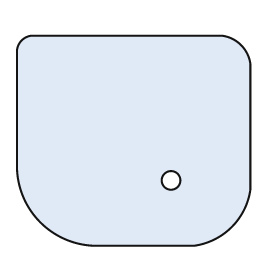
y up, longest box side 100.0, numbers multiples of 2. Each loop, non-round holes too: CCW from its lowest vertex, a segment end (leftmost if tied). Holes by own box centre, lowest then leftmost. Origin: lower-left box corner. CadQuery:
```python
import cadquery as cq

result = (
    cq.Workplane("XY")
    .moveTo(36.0, 0.0)
    .lineTo(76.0, 0.0)
    .threePointArc((92.0, 8.0), (100.0, 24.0))
    .lineTo(100.0, 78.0)
    .threePointArc((96.0, 86.0), (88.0, 90.0))
    .lineTo(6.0, 90.0)
    .threePointArc((2.0, 88.0), (0.0, 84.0))
    .lineTo(0.0, 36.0)
    .threePointArc((10.0, 10.0), (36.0, 0.0))
    .close()
    .moveTo(66.0, 28.0)
    .circle(4.0)
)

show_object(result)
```